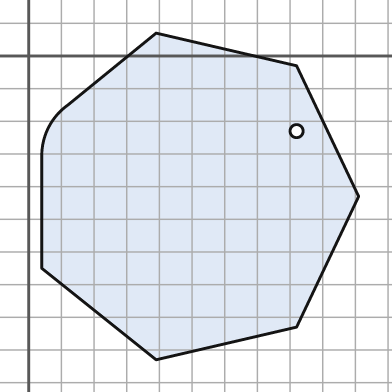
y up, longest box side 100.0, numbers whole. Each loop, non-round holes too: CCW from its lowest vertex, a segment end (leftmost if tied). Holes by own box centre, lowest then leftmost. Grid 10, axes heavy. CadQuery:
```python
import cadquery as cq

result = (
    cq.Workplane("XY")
    .moveTo(39.0, -93.0)
    .lineTo(82.0, -83.0)
    .lineTo(101.0, -43.0)
    .lineTo(82.0, -3.0)
    .lineTo(39.0, 7.0)
    .lineTo(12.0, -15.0)
    .threePointArc((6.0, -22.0), (4.0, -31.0))
    .lineTo(4.0, -65.0)
    .close()
    .moveTo(82.0, -23.0)
    .circle(2.0)
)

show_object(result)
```